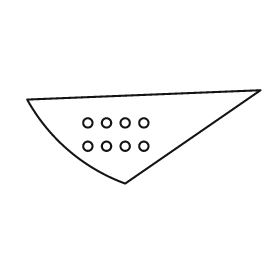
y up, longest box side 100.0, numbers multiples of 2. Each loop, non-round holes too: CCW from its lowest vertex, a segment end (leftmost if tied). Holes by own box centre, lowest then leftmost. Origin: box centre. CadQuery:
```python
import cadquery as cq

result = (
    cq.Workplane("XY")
    .moveTo(-8.0, -20.0)
    .lineTo(50.0, 20.0)
    .lineTo(-50.0, 16.0)
    .threePointArc((-32.0, -6.0), (-8.0, -20.0))
    .close()
    .moveTo(-24.0, -4.0)
    .circle(2.0)
    .moveTo(-16.0, -4.0)
    .circle(2.0)
    .moveTo(-8.0, -4.0)
    .circle(2.0)
    .moveTo(0.0, -4.0)
    .circle(2.0)
    .moveTo(-24.0, 6.0)
    .circle(2.0)
    .moveTo(-16.0, 6.0)
    .circle(2.0)
    .moveTo(-8.0, 6.0)
    .circle(2.0)
    .moveTo(0.0, 6.0)
    .circle(2.0)
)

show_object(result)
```